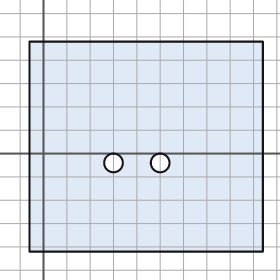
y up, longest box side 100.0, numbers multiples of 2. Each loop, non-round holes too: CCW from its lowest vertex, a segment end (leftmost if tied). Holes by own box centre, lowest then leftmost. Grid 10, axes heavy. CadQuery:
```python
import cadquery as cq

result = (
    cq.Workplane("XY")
    .moveTo(-6.0, -42.0)
    .lineTo(94.0, -42.0)
    .lineTo(94.0, 48.0)
    .lineTo(-6.0, 48.0)
    .close()
    .moveTo(30.0, -4.0)
    .circle(4.0)
    .moveTo(50.0, -4.0)
    .circle(4.0)
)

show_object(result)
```